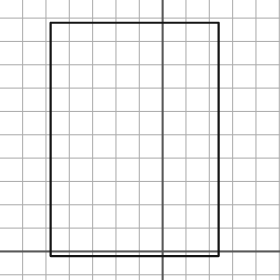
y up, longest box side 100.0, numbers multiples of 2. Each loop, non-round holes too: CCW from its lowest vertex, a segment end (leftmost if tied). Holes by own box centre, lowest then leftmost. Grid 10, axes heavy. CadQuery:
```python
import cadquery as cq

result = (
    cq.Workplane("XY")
    .moveTo(-48.0, -2.0)
    .lineTo(24.0, -2.0)
    .lineTo(24.0, 98.0)
    .lineTo(-48.0, 98.0)
    .close()
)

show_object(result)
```